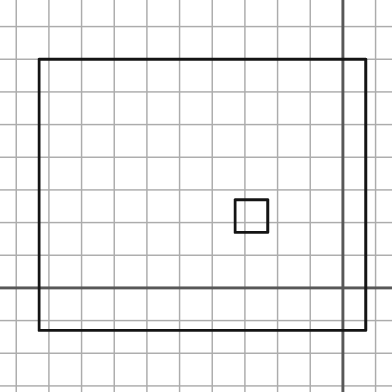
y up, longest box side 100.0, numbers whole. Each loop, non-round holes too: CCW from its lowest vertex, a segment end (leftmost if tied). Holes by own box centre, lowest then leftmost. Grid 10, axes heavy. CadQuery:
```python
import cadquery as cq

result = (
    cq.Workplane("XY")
    .moveTo(-93.0, -13.0)
    .lineTo(7.0, -13.0)
    .lineTo(7.0, 70.0)
    .lineTo(-93.0, 70.0)
    .close()
    .moveTo(-33.0, 17.0)
    .lineTo(-23.0, 17.0)
    .lineTo(-23.0, 27.0)
    .lineTo(-33.0, 27.0)
    .close()
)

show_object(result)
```